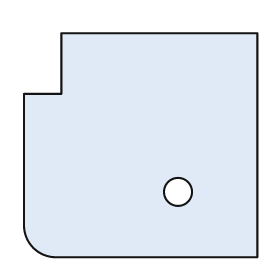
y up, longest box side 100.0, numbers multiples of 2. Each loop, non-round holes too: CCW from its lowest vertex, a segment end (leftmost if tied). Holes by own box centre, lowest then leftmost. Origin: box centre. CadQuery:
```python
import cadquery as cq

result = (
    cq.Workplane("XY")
    .moveTo(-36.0, -48.0)
    .lineTo(50.0, -48.0)
    .lineTo(50.0, 48.0)
    .lineTo(-34.0, 48.0)
    .lineTo(-34.0, 22.0)
    .lineTo(-50.0, 22.0)
    .lineTo(-50.0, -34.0)
    .threePointArc((-46.0, -44.0), (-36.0, -48.0))
    .close()
    .moveTo(16.0, -20.0)
    .circle(6.0)
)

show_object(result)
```